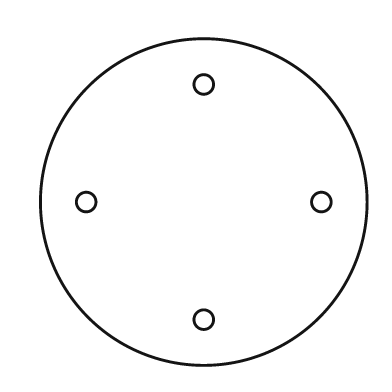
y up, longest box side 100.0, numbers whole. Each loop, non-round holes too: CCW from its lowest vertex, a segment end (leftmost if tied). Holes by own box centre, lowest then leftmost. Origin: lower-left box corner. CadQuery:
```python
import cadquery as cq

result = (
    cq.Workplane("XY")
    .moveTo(50.0, 50.0)
    .circle(50.0)
    .moveTo(50.0, 14.0)
    .circle(3.0)
    .moveTo(14.0, 50.0)
    .circle(3.0)
    .moveTo(86.0, 50.0)
    .circle(3.0)
    .moveTo(50.0, 86.0)
    .circle(3.0)
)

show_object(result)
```